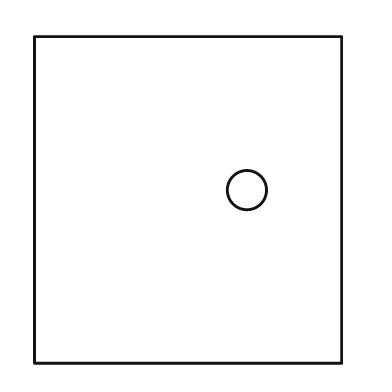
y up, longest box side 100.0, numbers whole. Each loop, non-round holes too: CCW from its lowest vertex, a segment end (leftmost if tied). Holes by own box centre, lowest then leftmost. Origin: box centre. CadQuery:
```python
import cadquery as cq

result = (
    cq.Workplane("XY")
    .moveTo(-47.0, -50.0)
    .lineTo(47.0, -50.0)
    .lineTo(47.0, 50.0)
    .lineTo(-47.0, 50.0)
    .close()
    .moveTo(18.0, 3.0)
    .circle(6.0)
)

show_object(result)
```